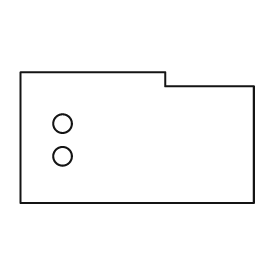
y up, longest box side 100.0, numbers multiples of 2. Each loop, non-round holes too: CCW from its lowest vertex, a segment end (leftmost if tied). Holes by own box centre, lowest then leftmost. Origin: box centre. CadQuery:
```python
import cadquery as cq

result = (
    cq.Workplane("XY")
    .moveTo(-50.0, -28.0)
    .lineTo(50.0, -28.0)
    .lineTo(50.0, 22.0)
    .lineTo(12.0, 22.0)
    .lineTo(12.0, 28.0)
    .lineTo(-50.0, 28.0)
    .close()
    .moveTo(-32.0, -8.0)
    .circle(4.0)
    .moveTo(-32.0, 6.0)
    .circle(4.0)
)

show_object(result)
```